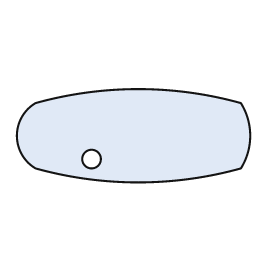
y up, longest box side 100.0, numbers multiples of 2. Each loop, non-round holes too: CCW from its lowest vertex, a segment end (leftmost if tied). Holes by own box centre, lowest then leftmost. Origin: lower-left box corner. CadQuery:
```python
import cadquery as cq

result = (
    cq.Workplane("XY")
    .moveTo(8.0, 6.0)
    .threePointArc((52.0, 0.0), (96.0, 6.0))
    .threePointArc((100.0, 20.0), (96.0, 34.0))
    .threePointArc((52.0, 40.0), (8.0, 34.0))
    .threePointArc((0.0, 20.0), (8.0, 6.0))
    .close()
    .moveTo(32.0, 10.0)
    .circle(4.0)
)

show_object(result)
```